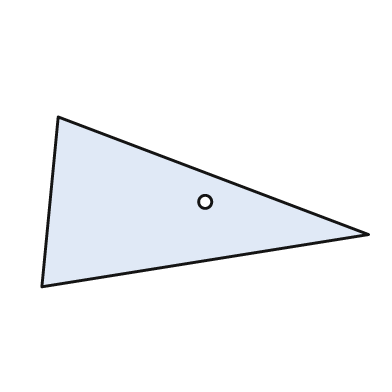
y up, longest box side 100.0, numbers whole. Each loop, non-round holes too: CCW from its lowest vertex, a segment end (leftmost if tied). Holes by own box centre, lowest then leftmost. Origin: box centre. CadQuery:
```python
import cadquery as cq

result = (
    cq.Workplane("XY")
    .moveTo(-50.0, -26.0)
    .lineTo(50.0, -10.0)
    .lineTo(-45.0, 26.0)
    .close()
    .moveTo(0.0, 0.0)
    .circle(2.0)
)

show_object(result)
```